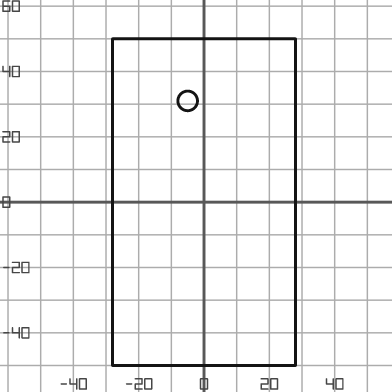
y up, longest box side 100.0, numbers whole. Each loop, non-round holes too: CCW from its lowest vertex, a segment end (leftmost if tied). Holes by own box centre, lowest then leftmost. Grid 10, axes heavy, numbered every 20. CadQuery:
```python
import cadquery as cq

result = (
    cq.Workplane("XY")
    .moveTo(-28.0, -50.0)
    .lineTo(28.0, -50.0)
    .lineTo(28.0, 50.0)
    .lineTo(-28.0, 50.0)
    .close()
    .moveTo(-5.0, 31.0)
    .circle(3.0)
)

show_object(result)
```